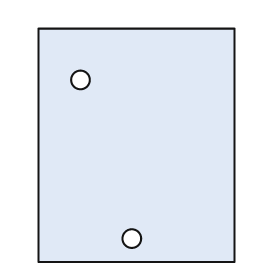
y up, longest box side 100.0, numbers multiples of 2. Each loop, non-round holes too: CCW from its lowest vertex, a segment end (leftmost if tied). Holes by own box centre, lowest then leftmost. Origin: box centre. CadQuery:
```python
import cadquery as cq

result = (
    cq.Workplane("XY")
    .moveTo(-42.0, -50.0)
    .lineTo(42.0, -50.0)
    .lineTo(42.0, 50.0)
    .lineTo(-42.0, 50.0)
    .close()
    .moveTo(-2.0, -40.0)
    .circle(4.0)
    .moveTo(-24.0, 28.0)
    .circle(4.0)
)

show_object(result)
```